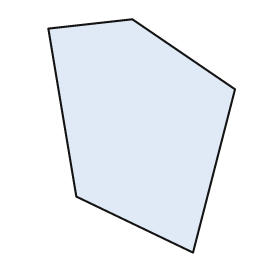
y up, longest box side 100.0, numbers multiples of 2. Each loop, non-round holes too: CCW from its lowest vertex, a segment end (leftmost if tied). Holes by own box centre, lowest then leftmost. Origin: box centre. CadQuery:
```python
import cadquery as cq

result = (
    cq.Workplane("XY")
    .moveTo(22.0, -50.0)
    .lineTo(40.0, 20.0)
    .lineTo(-4.0, 50.0)
    .lineTo(-40.0, 46.0)
    .lineTo(-28.0, -26.0)
    .close()
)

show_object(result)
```